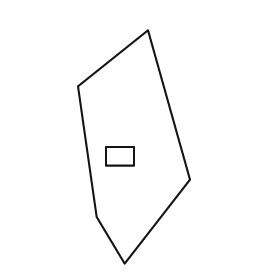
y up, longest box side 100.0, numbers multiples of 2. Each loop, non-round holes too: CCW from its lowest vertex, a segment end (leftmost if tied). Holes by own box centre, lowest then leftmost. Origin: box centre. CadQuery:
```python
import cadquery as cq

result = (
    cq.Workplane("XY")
    .moveTo(-4.0, -50.0)
    .lineTo(24.0, -14.0)
    .lineTo(6.0, 50.0)
    .lineTo(-24.0, 26.0)
    .lineTo(-16.0, -30.0)
    .close()
    .moveTo(-12.0, -8.0)
    .lineTo(0.0, -8.0)
    .lineTo(0.0, 0.0)
    .lineTo(-12.0, 0.0)
    .close()
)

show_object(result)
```